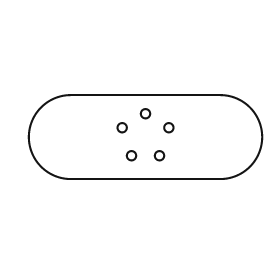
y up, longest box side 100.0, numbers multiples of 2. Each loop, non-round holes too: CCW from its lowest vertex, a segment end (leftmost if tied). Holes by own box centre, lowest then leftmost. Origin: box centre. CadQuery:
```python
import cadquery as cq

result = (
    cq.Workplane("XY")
    .moveTo(-32.0, -18.0)
    .lineTo(32.0, -18.0)
    .threePointArc((50.0, 0.0), (32.0, 18.0))
    .lineTo(-32.0, 18.0)
    .threePointArc((-50.0, 0.0), (-32.0, -18.0))
    .close()
    .moveTo(-6.0, -8.0)
    .circle(2.0)
    .moveTo(6.0, -8.0)
    .circle(2.0)
    .moveTo(-10.0, 4.0)
    .circle(2.0)
    .moveTo(10.0, 4.0)
    .circle(2.0)
    .moveTo(0.0, 10.0)
    .circle(2.0)
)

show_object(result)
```